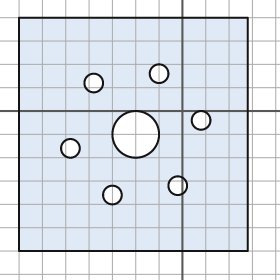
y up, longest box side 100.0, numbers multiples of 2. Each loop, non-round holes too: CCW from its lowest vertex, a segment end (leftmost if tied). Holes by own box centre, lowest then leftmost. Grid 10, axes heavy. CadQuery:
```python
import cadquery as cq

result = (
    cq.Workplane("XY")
    .moveTo(-70.0, -60.0)
    .lineTo(28.0, -60.0)
    .lineTo(28.0, 40.0)
    .lineTo(-70.0, 40.0)
    .close()
    .moveTo(-30.0, -36.0)
    .circle(4.0)
    .moveTo(-2.0, -32.0)
    .circle(4.0)
    .moveTo(-48.0, -16.0)
    .circle(4.0)
    .moveTo(-20.0, -10.0)
    .circle(10.0)
    .moveTo(8.0, -4.0)
    .circle(4.0)
    .moveTo(-38.0, 12.0)
    .circle(4.0)
    .moveTo(-10.0, 16.0)
    .circle(4.0)
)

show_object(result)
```